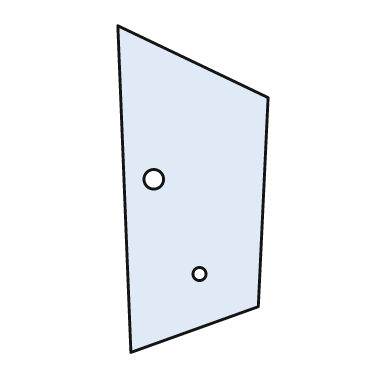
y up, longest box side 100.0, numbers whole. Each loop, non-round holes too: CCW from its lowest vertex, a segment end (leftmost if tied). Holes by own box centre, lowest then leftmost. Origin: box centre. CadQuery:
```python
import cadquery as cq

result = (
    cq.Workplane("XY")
    .moveTo(-19.0, -50.0)
    .lineTo(20.0, -36.0)
    .lineTo(23.0, 28.0)
    .lineTo(-23.0, 50.0)
    .close()
    .moveTo(2.0, -26.0)
    .circle(2.0)
    .moveTo(-12.0, 3.0)
    .circle(3.0)
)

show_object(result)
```